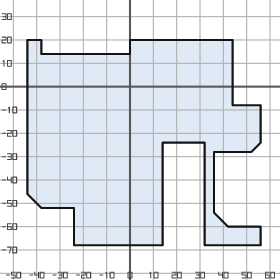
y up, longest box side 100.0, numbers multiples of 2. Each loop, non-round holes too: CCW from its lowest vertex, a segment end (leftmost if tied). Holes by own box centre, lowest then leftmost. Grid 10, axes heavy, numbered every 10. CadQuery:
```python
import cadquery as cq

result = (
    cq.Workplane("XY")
    .moveTo(-24.0, -68.0)
    .lineTo(14.0, -68.0)
    .lineTo(14.0, -24.0)
    .lineTo(32.0, -24.0)
    .lineTo(32.0, -68.0)
    .lineTo(56.0, -68.0)
    .lineTo(56.0, -60.0)
    .lineTo(42.0, -60.0)
    .lineTo(36.0, -54.0)
    .lineTo(36.0, -28.0)
    .lineTo(52.0, -28.0)
    .lineTo(56.0, -24.0)
    .lineTo(56.0, -8.0)
    .lineTo(44.0, -8.0)
    .lineTo(44.0, 20.0)
    .lineTo(0.0, 20.0)
    .lineTo(0.0, 14.0)
    .lineTo(-38.0, 14.0)
    .lineTo(-38.0, 20.0)
    .lineTo(-44.0, 20.0)
    .lineTo(-44.0, -46.0)
    .lineTo(-38.0, -52.0)
    .lineTo(-24.0, -52.0)
    .close()
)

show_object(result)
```